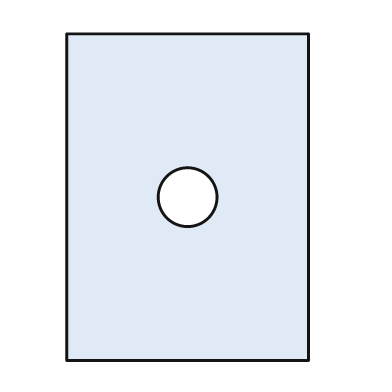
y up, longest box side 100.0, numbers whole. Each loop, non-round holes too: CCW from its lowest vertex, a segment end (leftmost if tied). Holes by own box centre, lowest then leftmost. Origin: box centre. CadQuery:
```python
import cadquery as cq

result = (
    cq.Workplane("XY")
    .moveTo(-37.0, -50.0)
    .lineTo(37.0, -50.0)
    .lineTo(37.0, 50.0)
    .lineTo(-37.0, 50.0)
    .close()
    .moveTo(0.0, 0.0)
    .circle(9.0)
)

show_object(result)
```